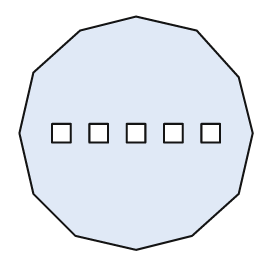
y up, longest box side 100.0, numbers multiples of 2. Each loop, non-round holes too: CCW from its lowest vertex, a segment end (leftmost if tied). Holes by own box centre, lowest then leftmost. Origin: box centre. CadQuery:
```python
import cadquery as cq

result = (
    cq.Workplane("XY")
    .moveTo(0.0, -50.0)
    .lineTo(24.0, -44.0)
    .lineTo(44.0, -26.0)
    .lineTo(50.0, 0.0)
    .lineTo(44.0, 24.0)
    .lineTo(26.0, 44.0)
    .lineTo(0.0, 50.0)
    .lineTo(-24.0, 44.0)
    .lineTo(-44.0, 26.0)
    .lineTo(-50.0, 0.0)
    .lineTo(-44.0, -26.0)
    .lineTo(-26.0, -44.0)
    .close()
    .moveTo(-36.0, -4.0)
    .lineTo(-28.0, -4.0)
    .lineTo(-28.0, 4.0)
    .lineTo(-36.0, 4.0)
    .close()
    .moveTo(-20.0, -4.0)
    .lineTo(-12.0, -4.0)
    .lineTo(-12.0, 4.0)
    .lineTo(-20.0, 4.0)
    .close()
    .moveTo(-4.0, -4.0)
    .lineTo(4.0, -4.0)
    .lineTo(4.0, 4.0)
    .lineTo(-4.0, 4.0)
    .close()
    .moveTo(12.0, -4.0)
    .lineTo(20.0, -4.0)
    .lineTo(20.0, 4.0)
    .lineTo(12.0, 4.0)
    .close()
    .moveTo(28.0, -4.0)
    .lineTo(36.0, -4.0)
    .lineTo(36.0, 4.0)
    .lineTo(28.0, 4.0)
    .close()
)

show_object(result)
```